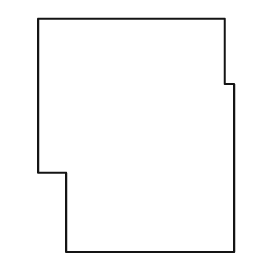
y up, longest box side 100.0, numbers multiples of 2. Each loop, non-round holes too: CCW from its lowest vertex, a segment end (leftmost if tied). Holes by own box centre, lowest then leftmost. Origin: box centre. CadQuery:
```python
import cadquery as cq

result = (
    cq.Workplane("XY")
    .moveTo(-30.0, -50.0)
    .lineTo(42.0, -50.0)
    .lineTo(42.0, 22.0)
    .lineTo(38.0, 22.0)
    .lineTo(38.0, 50.0)
    .lineTo(-42.0, 50.0)
    .lineTo(-42.0, -16.0)
    .lineTo(-30.0, -16.0)
    .close()
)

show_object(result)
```